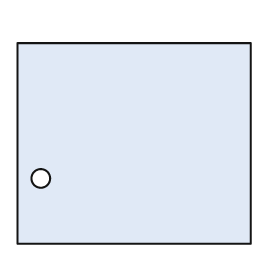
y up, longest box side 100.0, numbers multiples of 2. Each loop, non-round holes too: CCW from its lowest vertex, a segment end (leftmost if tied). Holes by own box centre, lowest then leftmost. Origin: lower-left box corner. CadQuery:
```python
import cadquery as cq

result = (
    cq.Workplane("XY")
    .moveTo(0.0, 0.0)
    .lineTo(100.0, 0.0)
    .lineTo(100.0, 86.0)
    .lineTo(0.0, 86.0)
    .close()
    .moveTo(10.0, 28.0)
    .circle(4.0)
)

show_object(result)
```